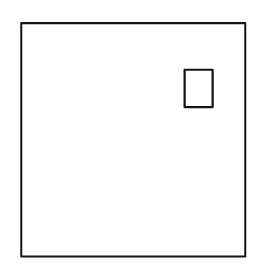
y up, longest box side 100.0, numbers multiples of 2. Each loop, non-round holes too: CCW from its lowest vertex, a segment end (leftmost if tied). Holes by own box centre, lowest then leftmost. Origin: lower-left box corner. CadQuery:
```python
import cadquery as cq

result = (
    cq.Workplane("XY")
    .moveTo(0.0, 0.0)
    .lineTo(96.0, 0.0)
    .lineTo(96.0, 100.0)
    .lineTo(0.0, 100.0)
    .close()
    .moveTo(70.0, 64.0)
    .lineTo(82.0, 64.0)
    .lineTo(82.0, 80.0)
    .lineTo(70.0, 80.0)
    .close()
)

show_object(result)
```